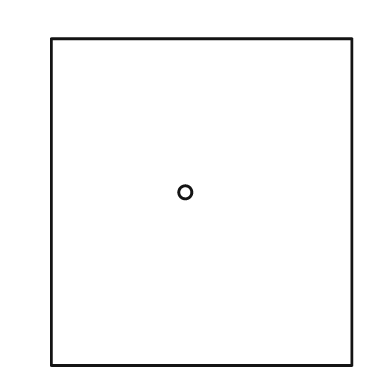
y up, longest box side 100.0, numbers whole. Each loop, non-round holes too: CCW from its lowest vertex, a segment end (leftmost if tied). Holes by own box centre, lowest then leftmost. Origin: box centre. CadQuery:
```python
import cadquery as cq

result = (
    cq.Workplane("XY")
    .moveTo(-46.0, -50.0)
    .lineTo(46.0, -50.0)
    .lineTo(46.0, 50.0)
    .lineTo(-46.0, 50.0)
    .close()
    .moveTo(-5.0, 3.0)
    .circle(2.0)
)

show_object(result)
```